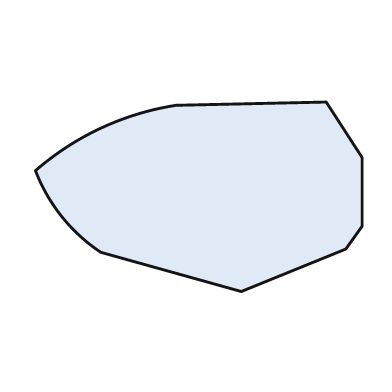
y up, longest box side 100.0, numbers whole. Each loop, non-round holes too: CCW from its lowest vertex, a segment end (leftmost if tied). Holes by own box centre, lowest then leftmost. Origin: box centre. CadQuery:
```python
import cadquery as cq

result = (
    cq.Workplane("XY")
    .moveTo(13.0, -29.0)
    .lineTo(45.0, -16.0)
    .lineTo(50.0, -9.0)
    .lineTo(50.0, 12.0)
    .lineTo(39.0, 29.0)
    .lineTo(-7.0, 28.0)
    .threePointArc((-30.0, 21.0), (-50.0, 8.0))
    .threePointArc((-42.0, -6.0), (-30.0, -17.0))
    .close()
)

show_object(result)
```